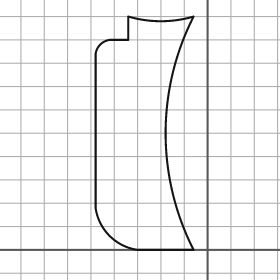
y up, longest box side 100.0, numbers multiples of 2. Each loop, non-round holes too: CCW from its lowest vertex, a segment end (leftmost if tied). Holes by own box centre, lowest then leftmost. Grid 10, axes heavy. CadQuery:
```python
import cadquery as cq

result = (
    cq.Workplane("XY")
    .moveTo(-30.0, 0.0)
    .lineTo(-6.0, 0.0)
    .threePointArc((-18.0, 50.0), (-6.0, 100.0))
    .threePointArc((-20.0, 98.0), (-34.0, 100.0))
    .lineTo(-34.0, 90.0)
    .lineTo(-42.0, 90.0)
    .threePointArc((-46.0, 88.0), (-48.0, 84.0))
    .lineTo(-48.0, 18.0)
    .threePointArc((-42.0, 6.0), (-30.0, 0.0))
    .close()
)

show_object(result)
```